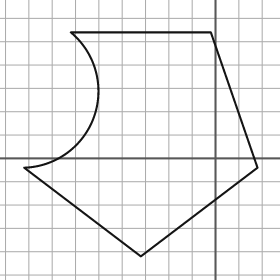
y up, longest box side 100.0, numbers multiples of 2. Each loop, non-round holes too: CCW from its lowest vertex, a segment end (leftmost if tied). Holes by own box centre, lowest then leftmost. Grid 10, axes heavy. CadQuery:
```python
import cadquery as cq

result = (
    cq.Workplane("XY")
    .moveTo(-32.0, -42.0)
    .lineTo(18.0, -4.0)
    .lineTo(-2.0, 54.0)
    .lineTo(-62.0, 54.0)
    .threePointArc((-52.0, 18.0), (-82.0, -4.0))
    .close()
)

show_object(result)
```